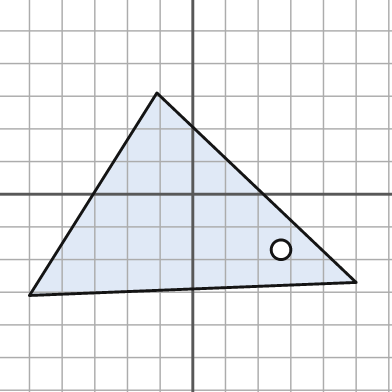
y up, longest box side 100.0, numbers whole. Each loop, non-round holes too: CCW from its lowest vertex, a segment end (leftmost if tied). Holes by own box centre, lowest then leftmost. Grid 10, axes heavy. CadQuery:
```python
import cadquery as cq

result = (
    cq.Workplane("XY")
    .moveTo(-50.0, -31.0)
    .lineTo(50.0, -27.0)
    .lineTo(-11.0, 31.0)
    .close()
    .moveTo(27.0, -17.0)
    .circle(3.0)
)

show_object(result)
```